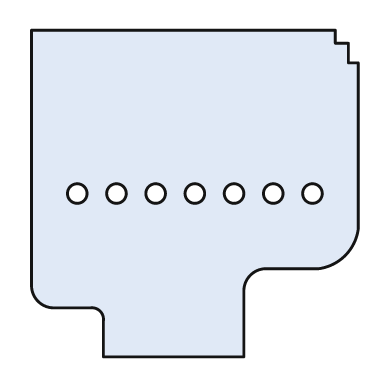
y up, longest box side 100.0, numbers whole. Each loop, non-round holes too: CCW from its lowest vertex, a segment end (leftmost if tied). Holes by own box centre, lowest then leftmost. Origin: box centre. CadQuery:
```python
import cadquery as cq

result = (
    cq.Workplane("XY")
    .moveTo(-28.0, -50.0)
    .lineTo(15.0, -50.0)
    .lineTo(15.0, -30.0)
    .threePointArc((17.0, -25.0), (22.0, -23.0))
    .lineTo(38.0, -23.0)
    .threePointArc((46.0, -19.0), (50.0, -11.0))
    .lineTo(50.0, 40.0)
    .lineTo(47.0, 40.0)
    .lineTo(47.0, 46.0)
    .lineTo(43.0, 46.0)
    .lineTo(43.0, 50.0)
    .lineTo(-50.0, 50.0)
    .lineTo(-50.0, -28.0)
    .threePointArc((-48.0, -33.0), (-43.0, -35.0))
    .lineTo(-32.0, -35.0)
    .threePointArc((-29.0, -36.0), (-28.0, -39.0))
    .close()
    .moveTo(-36.0, 0.0)
    .circle(3.0)
    .moveTo(-24.0, 0.0)
    .circle(3.0)
    .moveTo(-12.0, 0.0)
    .circle(3.0)
    .moveTo(0.0, 0.0)
    .circle(3.0)
    .moveTo(12.0, 0.0)
    .circle(3.0)
    .moveTo(24.0, 0.0)
    .circle(3.0)
    .moveTo(36.0, 0.0)
    .circle(3.0)
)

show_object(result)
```